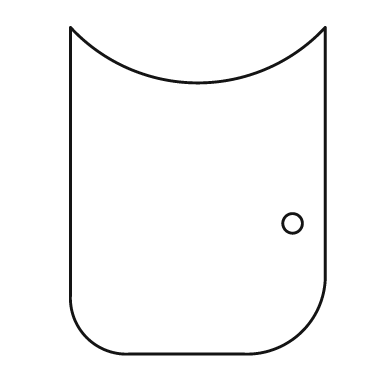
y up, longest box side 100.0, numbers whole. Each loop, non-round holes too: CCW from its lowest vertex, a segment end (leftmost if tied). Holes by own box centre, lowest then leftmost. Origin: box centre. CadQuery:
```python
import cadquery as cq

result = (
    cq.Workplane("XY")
    .moveTo(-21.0, -50.0)
    .lineTo(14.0, -50.0)
    .threePointArc((32.0, -43.0), (39.0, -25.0))
    .lineTo(39.0, 50.0)
    .threePointArc((0.0, 33.0), (-39.0, 50.0))
    .lineTo(-39.0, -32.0)
    .threePointArc((-34.0, -45.0), (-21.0, -50.0))
    .close()
    .moveTo(29.0, -10.0)
    .circle(3.0)
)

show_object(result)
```